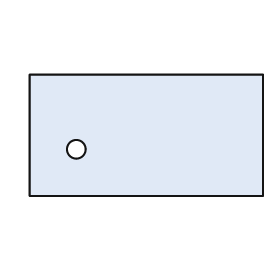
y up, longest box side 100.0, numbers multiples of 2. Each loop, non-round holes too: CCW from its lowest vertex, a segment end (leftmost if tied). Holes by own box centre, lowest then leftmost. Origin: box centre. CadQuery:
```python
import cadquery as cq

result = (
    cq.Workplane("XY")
    .moveTo(-50.0, -26.0)
    .lineTo(50.0, -26.0)
    .lineTo(50.0, 26.0)
    .lineTo(-50.0, 26.0)
    .close()
    .moveTo(-30.0, -6.0)
    .circle(4.0)
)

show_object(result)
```